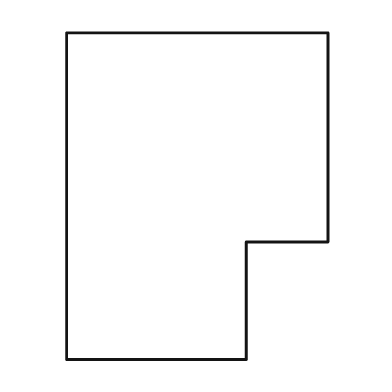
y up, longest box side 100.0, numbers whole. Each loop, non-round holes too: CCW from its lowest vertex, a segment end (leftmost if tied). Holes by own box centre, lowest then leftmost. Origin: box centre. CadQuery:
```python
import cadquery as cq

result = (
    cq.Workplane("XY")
    .moveTo(-40.0, -50.0)
    .lineTo(15.0, -50.0)
    .lineTo(15.0, -14.0)
    .lineTo(40.0, -14.0)
    .lineTo(40.0, 50.0)
    .lineTo(-40.0, 50.0)
    .close()
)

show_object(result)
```